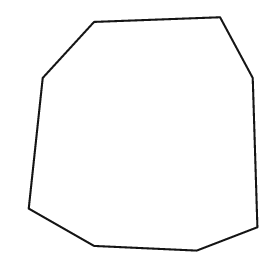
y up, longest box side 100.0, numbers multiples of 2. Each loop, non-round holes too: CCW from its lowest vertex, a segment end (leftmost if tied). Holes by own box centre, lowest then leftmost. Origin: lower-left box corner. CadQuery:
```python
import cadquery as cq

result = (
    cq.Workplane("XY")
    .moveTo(72.0, 0.0)
    .lineTo(98.0, 10.0)
    .lineTo(96.0, 74.0)
    .lineTo(82.0, 100.0)
    .lineTo(28.0, 98.0)
    .lineTo(6.0, 74.0)
    .lineTo(0.0, 18.0)
    .lineTo(28.0, 2.0)
    .close()
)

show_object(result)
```